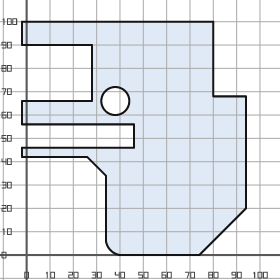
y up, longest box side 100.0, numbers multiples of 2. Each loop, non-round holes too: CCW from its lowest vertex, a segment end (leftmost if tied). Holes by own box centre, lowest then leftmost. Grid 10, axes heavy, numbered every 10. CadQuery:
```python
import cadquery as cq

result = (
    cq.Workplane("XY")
    .moveTo(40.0, 0.0)
    .lineTo(74.0, 0.0)
    .lineTo(94.0, 20.0)
    .lineTo(94.0, 68.0)
    .lineTo(80.0, 68.0)
    .lineTo(80.0, 100.0)
    .lineTo(-2.0, 100.0)
    .lineTo(-2.0, 90.0)
    .lineTo(28.0, 90.0)
    .lineTo(28.0, 66.0)
    .lineTo(-2.0, 66.0)
    .lineTo(-2.0, 56.0)
    .lineTo(46.0, 56.0)
    .lineTo(46.0, 46.0)
    .lineTo(-2.0, 46.0)
    .lineTo(-2.0, 42.0)
    .lineTo(26.0, 42.0)
    .lineTo(34.0, 34.0)
    .lineTo(34.0, 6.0)
    .threePointArc((36.0, 2.0), (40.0, 0.0))
    .close()
    .moveTo(38.0, 66.0)
    .circle(6.0)
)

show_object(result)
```